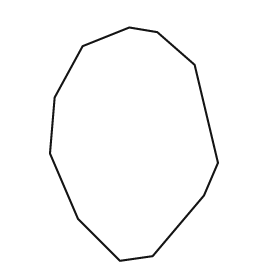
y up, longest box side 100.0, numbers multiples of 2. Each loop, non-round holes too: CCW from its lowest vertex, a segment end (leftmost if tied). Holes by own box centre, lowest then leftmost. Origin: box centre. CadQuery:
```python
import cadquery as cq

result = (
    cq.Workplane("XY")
    .moveTo(-6.0, -50.0)
    .lineTo(8.0, -48.0)
    .lineTo(30.0, -22.0)
    .lineTo(36.0, -8.0)
    .lineTo(26.0, 34.0)
    .lineTo(10.0, 48.0)
    .lineTo(-2.0, 50.0)
    .lineTo(-22.0, 42.0)
    .lineTo(-34.0, 20.0)
    .lineTo(-36.0, -4.0)
    .lineTo(-24.0, -32.0)
    .close()
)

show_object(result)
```